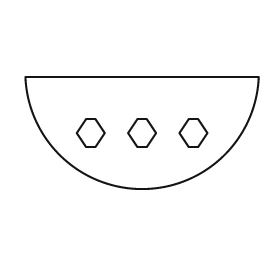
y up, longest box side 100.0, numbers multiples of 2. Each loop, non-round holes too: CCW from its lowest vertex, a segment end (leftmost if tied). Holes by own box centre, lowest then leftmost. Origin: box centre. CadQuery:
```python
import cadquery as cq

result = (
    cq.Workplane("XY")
    .moveTo(-50.0, 24.0)
    .threePointArc((0.0, -24.0), (50.0, 24.0))
    .close()
    .moveTo(-24.0, -6.0)
    .lineTo(-20.0, -6.0)
    .lineTo(-16.0, 0.0)
    .lineTo(-20.0, 6.0)
    .lineTo(-24.0, 6.0)
    .lineTo(-28.0, 0.0)
    .close()
    .moveTo(-2.0, -6.0)
    .lineTo(2.0, -6.0)
    .lineTo(6.0, 0.0)
    .lineTo(2.0, 6.0)
    .lineTo(-2.0, 6.0)
    .lineTo(-6.0, 0.0)
    .close()
    .moveTo(20.0, -6.0)
    .lineTo(24.0, -6.0)
    .lineTo(28.0, 0.0)
    .lineTo(24.0, 6.0)
    .lineTo(20.0, 6.0)
    .lineTo(16.0, 0.0)
    .close()
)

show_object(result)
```